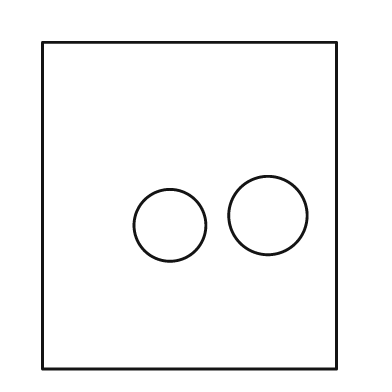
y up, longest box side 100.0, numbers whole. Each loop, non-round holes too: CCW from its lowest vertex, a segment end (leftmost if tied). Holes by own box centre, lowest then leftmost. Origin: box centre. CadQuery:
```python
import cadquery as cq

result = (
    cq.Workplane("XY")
    .moveTo(-45.0, -50.0)
    .lineTo(45.0, -50.0)
    .lineTo(45.0, 50.0)
    .lineTo(-45.0, 50.0)
    .close()
    .moveTo(-6.0, -6.0)
    .circle(11.0)
    .moveTo(24.0, -3.0)
    .circle(12.0)
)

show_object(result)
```